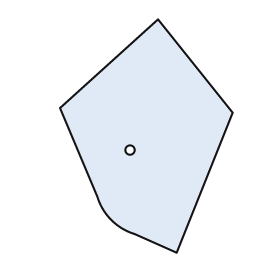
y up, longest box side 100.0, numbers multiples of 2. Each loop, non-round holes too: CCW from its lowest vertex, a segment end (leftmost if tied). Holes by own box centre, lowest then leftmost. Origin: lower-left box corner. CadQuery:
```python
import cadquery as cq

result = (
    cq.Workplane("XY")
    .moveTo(50.0, 0.0)
    .lineTo(74.0, 60.0)
    .lineTo(42.0, 100.0)
    .lineTo(0.0, 62.0)
    .lineTo(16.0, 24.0)
    .threePointArc((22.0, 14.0), (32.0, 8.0))
    .close()
    .moveTo(30.0, 44.0)
    .circle(2.0)
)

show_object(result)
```